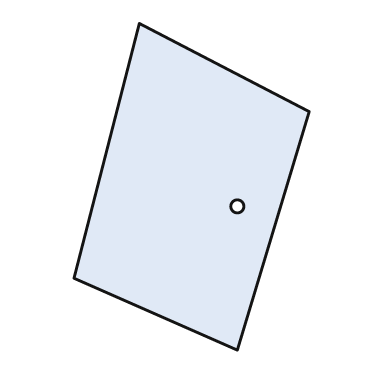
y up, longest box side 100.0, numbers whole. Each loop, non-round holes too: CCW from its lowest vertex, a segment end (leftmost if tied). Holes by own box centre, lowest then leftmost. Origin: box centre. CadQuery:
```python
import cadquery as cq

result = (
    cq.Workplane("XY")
    .moveTo(14.0, -50.0)
    .lineTo(36.0, 23.0)
    .lineTo(-16.0, 50.0)
    .lineTo(-36.0, -28.0)
    .close()
    .moveTo(14.0, -6.0)
    .circle(2.0)
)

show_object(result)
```